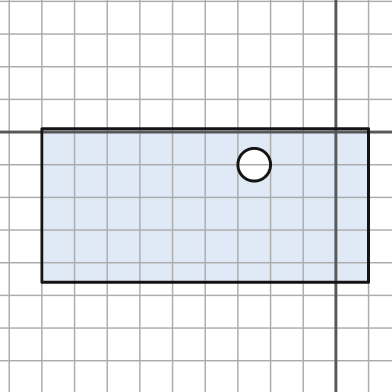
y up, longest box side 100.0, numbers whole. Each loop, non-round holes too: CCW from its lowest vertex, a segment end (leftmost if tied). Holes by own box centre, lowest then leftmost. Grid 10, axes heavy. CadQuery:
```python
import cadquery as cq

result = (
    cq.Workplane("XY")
    .moveTo(-90.0, -46.0)
    .lineTo(10.0, -46.0)
    .lineTo(10.0, 1.0)
    .lineTo(-90.0, 1.0)
    .close()
    .moveTo(-25.0, -10.0)
    .circle(5.0)
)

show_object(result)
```